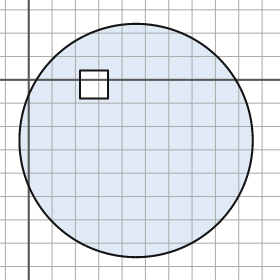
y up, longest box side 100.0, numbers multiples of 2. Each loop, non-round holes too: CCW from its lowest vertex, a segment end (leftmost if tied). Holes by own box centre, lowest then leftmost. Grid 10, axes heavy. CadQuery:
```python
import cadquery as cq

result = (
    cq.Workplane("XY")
    .moveTo(46.0, -26.0)
    .circle(50.0)
    .moveTo(22.0, -8.0)
    .lineTo(34.0, -8.0)
    .lineTo(34.0, 4.0)
    .lineTo(22.0, 4.0)
    .close()
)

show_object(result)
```